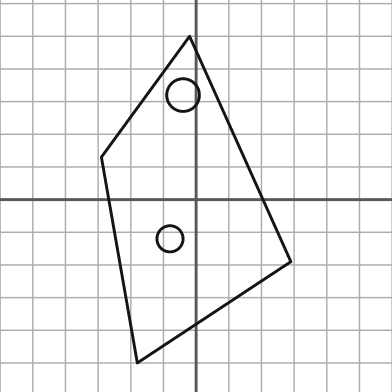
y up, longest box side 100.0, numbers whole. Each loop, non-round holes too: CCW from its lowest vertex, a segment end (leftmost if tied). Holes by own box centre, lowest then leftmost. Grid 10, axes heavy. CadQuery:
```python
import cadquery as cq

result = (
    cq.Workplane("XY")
    .moveTo(-18.0, -50.0)
    .lineTo(29.0, -19.0)
    .lineTo(-2.0, 50.0)
    .lineTo(-29.0, 13.0)
    .close()
    .moveTo(-8.0, -12.0)
    .circle(4.0)
    .moveTo(-4.0, 32.0)
    .circle(5.0)
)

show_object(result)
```